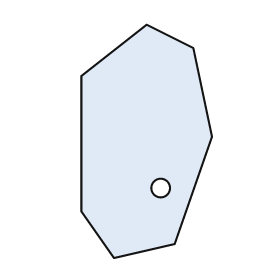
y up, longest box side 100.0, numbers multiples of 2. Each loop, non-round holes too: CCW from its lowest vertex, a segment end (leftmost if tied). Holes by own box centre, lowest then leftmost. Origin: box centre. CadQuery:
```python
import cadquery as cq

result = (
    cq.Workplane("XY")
    .moveTo(-14.0, -50.0)
    .lineTo(12.0, -44.0)
    .lineTo(28.0, 2.0)
    .lineTo(20.0, 40.0)
    .lineTo(0.0, 50.0)
    .lineTo(-28.0, 28.0)
    .lineTo(-28.0, -30.0)
    .close()
    .moveTo(6.0, -20.0)
    .circle(4.0)
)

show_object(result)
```